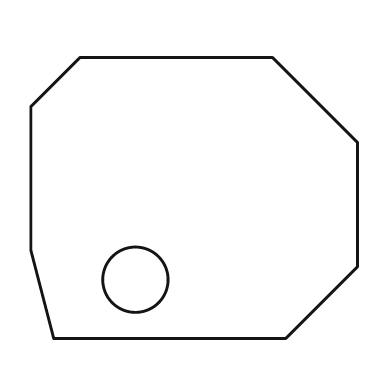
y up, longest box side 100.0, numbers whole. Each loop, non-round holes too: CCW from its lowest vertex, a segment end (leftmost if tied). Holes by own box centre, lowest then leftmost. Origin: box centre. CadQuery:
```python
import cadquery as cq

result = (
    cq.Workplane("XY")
    .moveTo(-43.0, -43.0)
    .lineTo(28.0, -43.0)
    .lineTo(50.0, -21.0)
    .lineTo(50.0, 17.0)
    .lineTo(24.0, 43.0)
    .lineTo(-35.0, 43.0)
    .lineTo(-50.0, 28.0)
    .lineTo(-50.0, -16.0)
    .close()
    .moveTo(-18.0, -25.0)
    .circle(10.0)
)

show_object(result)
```